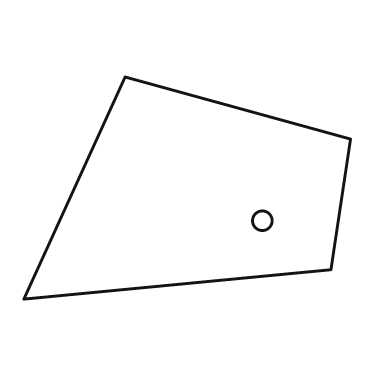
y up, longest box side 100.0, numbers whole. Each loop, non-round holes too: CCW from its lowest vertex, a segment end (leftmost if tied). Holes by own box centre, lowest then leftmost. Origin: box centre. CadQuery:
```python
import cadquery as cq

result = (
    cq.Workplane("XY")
    .moveTo(-50.0, -34.0)
    .lineTo(44.0, -25.0)
    .lineTo(50.0, 15.0)
    .lineTo(-19.0, 34.0)
    .close()
    .moveTo(23.0, -10.0)
    .circle(3.0)
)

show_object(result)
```